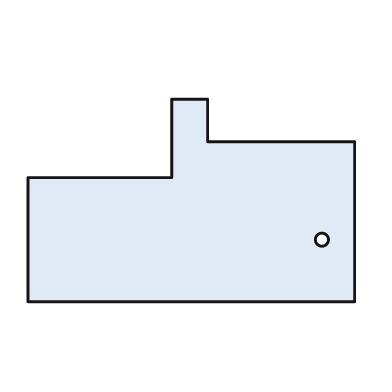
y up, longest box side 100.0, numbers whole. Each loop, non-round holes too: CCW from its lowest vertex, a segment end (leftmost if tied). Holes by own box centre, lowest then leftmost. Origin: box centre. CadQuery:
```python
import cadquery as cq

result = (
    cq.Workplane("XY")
    .moveTo(-50.0, -31.0)
    .lineTo(50.0, -31.0)
    .lineTo(50.0, 18.0)
    .lineTo(5.0, 18.0)
    .lineTo(5.0, 31.0)
    .lineTo(-6.0, 31.0)
    .lineTo(-6.0, 7.0)
    .lineTo(-50.0, 7.0)
    .close()
    .moveTo(40.0, -12.0)
    .circle(2.0)
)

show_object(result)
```